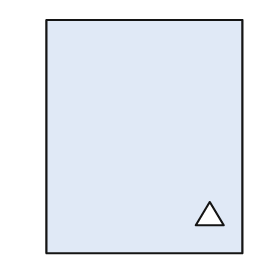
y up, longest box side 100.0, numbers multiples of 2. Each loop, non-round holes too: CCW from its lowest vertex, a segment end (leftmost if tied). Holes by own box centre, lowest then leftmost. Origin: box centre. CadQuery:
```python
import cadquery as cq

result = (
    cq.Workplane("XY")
    .moveTo(-42.0, -50.0)
    .lineTo(42.0, -50.0)
    .lineTo(42.0, 50.0)
    .lineTo(-42.0, 50.0)
    .close()
    .moveTo(22.0, -38.0)
    .lineTo(34.0, -38.0)
    .lineTo(28.0, -28.0)
    .close()
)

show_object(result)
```